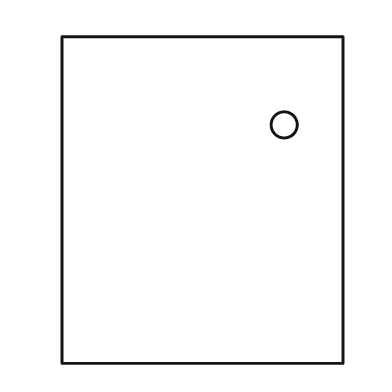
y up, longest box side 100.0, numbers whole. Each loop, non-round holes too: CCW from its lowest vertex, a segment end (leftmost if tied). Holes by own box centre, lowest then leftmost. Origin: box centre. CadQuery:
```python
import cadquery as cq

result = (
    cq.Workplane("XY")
    .moveTo(-43.0, -50.0)
    .lineTo(43.0, -50.0)
    .lineTo(43.0, 50.0)
    .lineTo(-43.0, 50.0)
    .close()
    .moveTo(25.0, 23.0)
    .circle(4.0)
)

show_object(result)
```